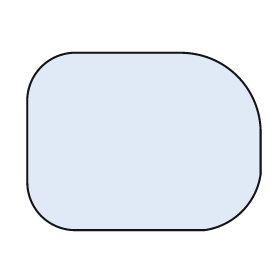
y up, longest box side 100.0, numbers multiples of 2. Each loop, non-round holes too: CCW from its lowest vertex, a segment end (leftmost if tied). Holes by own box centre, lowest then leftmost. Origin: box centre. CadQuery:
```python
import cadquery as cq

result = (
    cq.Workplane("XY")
    .moveTo(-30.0, -38.0)
    .lineTo(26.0, -38.0)
    .threePointArc((42.0, -30.0), (50.0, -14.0))
    .lineTo(50.0, 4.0)
    .threePointArc((40.0, 28.0), (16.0, 38.0))
    .lineTo(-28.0, 38.0)
    .threePointArc((-44.0, 32.0), (-50.0, 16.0))
    .lineTo(-50.0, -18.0)
    .threePointArc((-44.0, -32.0), (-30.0, -38.0))
    .close()
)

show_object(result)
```